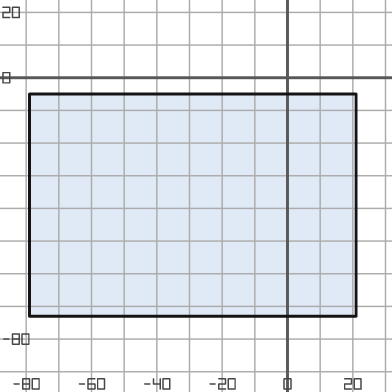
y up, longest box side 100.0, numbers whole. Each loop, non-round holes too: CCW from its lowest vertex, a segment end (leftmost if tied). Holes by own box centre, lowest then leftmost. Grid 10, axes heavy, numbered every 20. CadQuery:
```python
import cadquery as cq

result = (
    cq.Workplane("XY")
    .moveTo(-79.0, -73.0)
    .lineTo(21.0, -73.0)
    .lineTo(21.0, -5.0)
    .lineTo(-79.0, -5.0)
    .close()
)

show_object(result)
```